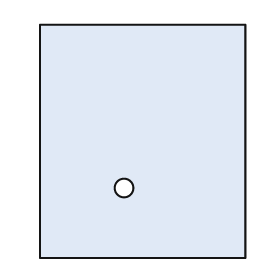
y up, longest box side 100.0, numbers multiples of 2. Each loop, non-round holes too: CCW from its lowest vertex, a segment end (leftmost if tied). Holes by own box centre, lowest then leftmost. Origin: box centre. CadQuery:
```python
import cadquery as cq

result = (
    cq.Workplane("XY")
    .moveTo(-44.0, -50.0)
    .lineTo(44.0, -50.0)
    .lineTo(44.0, 50.0)
    .lineTo(-44.0, 50.0)
    .close()
    .moveTo(-8.0, -20.0)
    .circle(4.0)
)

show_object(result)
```